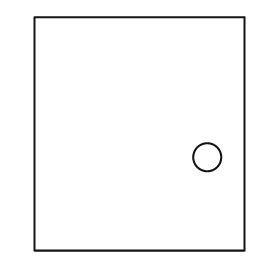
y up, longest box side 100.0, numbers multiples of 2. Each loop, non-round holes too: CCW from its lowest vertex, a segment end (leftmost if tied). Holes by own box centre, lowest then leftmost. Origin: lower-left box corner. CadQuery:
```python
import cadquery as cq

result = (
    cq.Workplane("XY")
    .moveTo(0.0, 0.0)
    .lineTo(90.0, 0.0)
    .lineTo(90.0, 100.0)
    .lineTo(0.0, 100.0)
    .close()
    .moveTo(74.0, 40.0)
    .circle(6.0)
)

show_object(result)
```